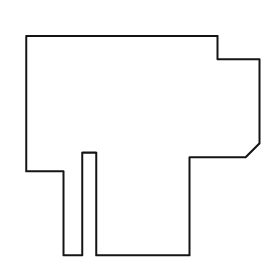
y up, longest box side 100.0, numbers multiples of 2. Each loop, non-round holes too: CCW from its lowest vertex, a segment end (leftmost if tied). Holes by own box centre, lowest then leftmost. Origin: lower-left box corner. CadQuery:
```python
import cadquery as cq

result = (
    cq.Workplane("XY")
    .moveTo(16.0, 0.0)
    .lineTo(24.0, 0.0)
    .lineTo(24.0, 44.0)
    .lineTo(30.0, 44.0)
    .lineTo(30.0, 0.0)
    .lineTo(70.0, 0.0)
    .lineTo(70.0, 42.0)
    .lineTo(94.0, 42.0)
    .lineTo(100.0, 48.0)
    .lineTo(100.0, 84.0)
    .lineTo(82.0, 84.0)
    .lineTo(82.0, 94.0)
    .lineTo(0.0, 94.0)
    .lineTo(0.0, 36.0)
    .lineTo(16.0, 36.0)
    .close()
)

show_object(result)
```